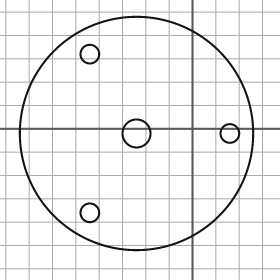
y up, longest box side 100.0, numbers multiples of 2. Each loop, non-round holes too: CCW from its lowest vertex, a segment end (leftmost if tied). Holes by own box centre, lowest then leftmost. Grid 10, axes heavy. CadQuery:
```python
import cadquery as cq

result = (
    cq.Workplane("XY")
    .moveTo(-24.0, -2.0)
    .circle(50.0)
    .moveTo(-44.0, -36.0)
    .circle(4.0)
    .moveTo(-24.0, -2.0)
    .circle(6.0)
    .moveTo(16.0, -2.0)
    .circle(4.0)
    .moveTo(-44.0, 32.0)
    .circle(4.0)
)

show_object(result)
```